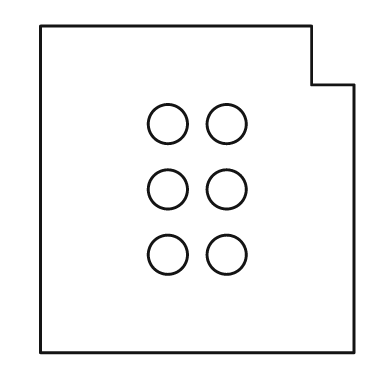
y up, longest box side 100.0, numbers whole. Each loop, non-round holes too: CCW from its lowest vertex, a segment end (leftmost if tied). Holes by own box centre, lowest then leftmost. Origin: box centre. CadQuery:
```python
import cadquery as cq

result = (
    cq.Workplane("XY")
    .moveTo(-48.0, -50.0)
    .lineTo(48.0, -50.0)
    .lineTo(48.0, 32.0)
    .lineTo(35.0, 32.0)
    .lineTo(35.0, 50.0)
    .lineTo(-48.0, 50.0)
    .close()
    .moveTo(-9.0, -20.0)
    .circle(6.0)
    .moveTo(9.0, -20.0)
    .circle(6.0)
    .moveTo(-9.0, 0.0)
    .circle(6.0)
    .moveTo(9.0, 0.0)
    .circle(6.0)
    .moveTo(-9.0, 20.0)
    .circle(6.0)
    .moveTo(9.0, 20.0)
    .circle(6.0)
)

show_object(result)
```